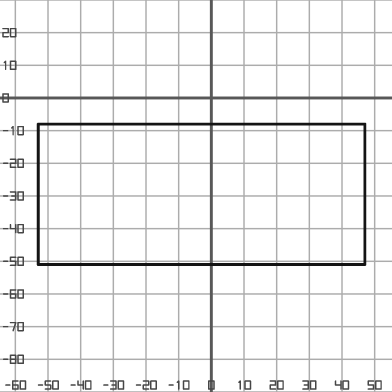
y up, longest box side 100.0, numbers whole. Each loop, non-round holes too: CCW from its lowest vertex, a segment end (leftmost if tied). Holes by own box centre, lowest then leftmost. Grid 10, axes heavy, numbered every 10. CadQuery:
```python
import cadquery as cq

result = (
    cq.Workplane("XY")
    .moveTo(-53.0, -51.0)
    .lineTo(47.0, -51.0)
    .lineTo(47.0, -8.0)
    .lineTo(-53.0, -8.0)
    .close()
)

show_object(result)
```